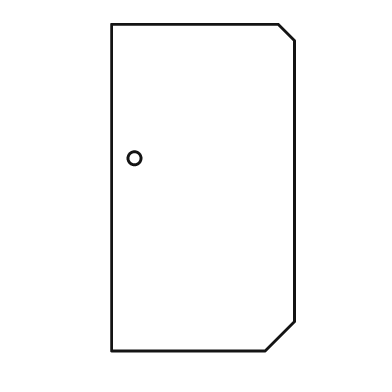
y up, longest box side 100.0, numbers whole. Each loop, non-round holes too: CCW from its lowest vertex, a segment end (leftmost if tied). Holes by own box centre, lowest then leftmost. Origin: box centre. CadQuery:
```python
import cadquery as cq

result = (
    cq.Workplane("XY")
    .moveTo(-28.0, -50.0)
    .lineTo(19.0, -50.0)
    .lineTo(28.0, -41.0)
    .lineTo(28.0, 45.0)
    .lineTo(23.0, 50.0)
    .lineTo(-28.0, 50.0)
    .close()
    .moveTo(-21.0, 9.0)
    .circle(2.0)
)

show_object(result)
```